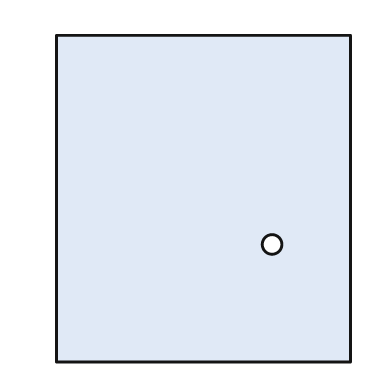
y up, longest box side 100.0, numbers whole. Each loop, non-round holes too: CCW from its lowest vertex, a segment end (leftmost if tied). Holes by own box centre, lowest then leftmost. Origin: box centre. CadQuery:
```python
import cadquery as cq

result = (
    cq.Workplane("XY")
    .moveTo(-45.0, -50.0)
    .lineTo(45.0, -50.0)
    .lineTo(45.0, 50.0)
    .lineTo(-45.0, 50.0)
    .close()
    .moveTo(21.0, -14.0)
    .circle(3.0)
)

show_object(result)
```